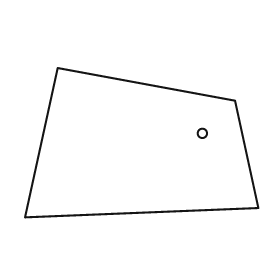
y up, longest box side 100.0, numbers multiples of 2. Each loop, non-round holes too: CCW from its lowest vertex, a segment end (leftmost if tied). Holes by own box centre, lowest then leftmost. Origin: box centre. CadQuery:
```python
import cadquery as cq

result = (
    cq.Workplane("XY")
    .moveTo(-50.0, -32.0)
    .lineTo(50.0, -28.0)
    .lineTo(40.0, 18.0)
    .lineTo(-36.0, 32.0)
    .close()
    .moveTo(26.0, 4.0)
    .circle(2.0)
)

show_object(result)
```